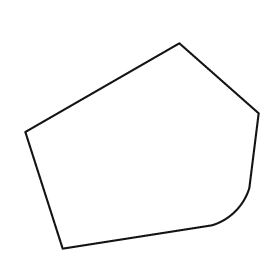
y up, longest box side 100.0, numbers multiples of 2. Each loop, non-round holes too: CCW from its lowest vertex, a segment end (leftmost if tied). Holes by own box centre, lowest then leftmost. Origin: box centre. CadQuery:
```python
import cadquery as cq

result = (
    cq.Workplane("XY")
    .moveTo(-34.0, -44.0)
    .lineTo(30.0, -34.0)
    .threePointArc((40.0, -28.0), (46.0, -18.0))
    .lineTo(50.0, 14.0)
    .lineTo(16.0, 44.0)
    .lineTo(-50.0, 6.0)
    .close()
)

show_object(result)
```